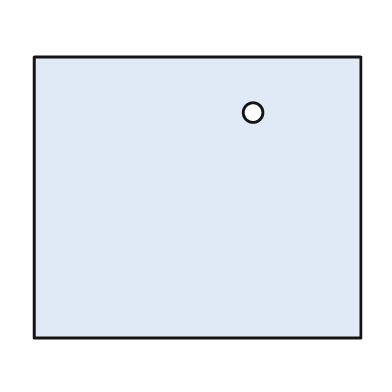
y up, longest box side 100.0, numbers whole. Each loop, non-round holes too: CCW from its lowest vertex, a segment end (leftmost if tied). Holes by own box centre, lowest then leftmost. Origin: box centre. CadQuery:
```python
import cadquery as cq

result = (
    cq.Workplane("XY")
    .moveTo(-50.0, -43.0)
    .lineTo(50.0, -43.0)
    .lineTo(50.0, 43.0)
    .lineTo(-50.0, 43.0)
    .close()
    .moveTo(17.0, 26.0)
    .circle(3.0)
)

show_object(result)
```